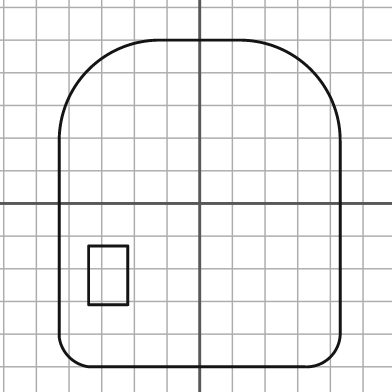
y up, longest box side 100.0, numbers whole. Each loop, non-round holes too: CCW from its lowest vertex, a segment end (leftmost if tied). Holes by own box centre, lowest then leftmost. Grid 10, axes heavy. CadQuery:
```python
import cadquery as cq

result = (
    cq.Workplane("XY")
    .moveTo(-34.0, -50.0)
    .lineTo(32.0, -50.0)
    .threePointArc((40.0, -47.0), (43.0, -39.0))
    .lineTo(43.0, 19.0)
    .threePointArc((34.0, 41.0), (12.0, 50.0))
    .lineTo(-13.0, 50.0)
    .threePointArc((-34.0, 41.0), (-43.0, 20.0))
    .lineTo(-43.0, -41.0)
    .threePointArc((-40.0, -47.0), (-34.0, -50.0))
    .close()
    .moveTo(-34.0, -31.0)
    .lineTo(-22.0, -31.0)
    .lineTo(-22.0, -13.0)
    .lineTo(-34.0, -13.0)
    .close()
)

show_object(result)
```